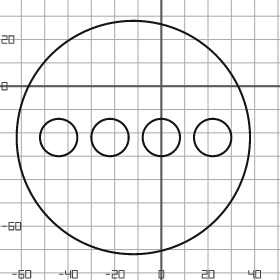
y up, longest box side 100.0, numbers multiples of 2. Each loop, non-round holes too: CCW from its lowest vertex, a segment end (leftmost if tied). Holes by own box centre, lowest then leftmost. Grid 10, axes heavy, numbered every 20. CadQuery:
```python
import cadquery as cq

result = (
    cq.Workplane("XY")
    .moveTo(-12.0, -22.0)
    .circle(50.0)
    .moveTo(-44.0, -22.0)
    .circle(8.0)
    .moveTo(-22.0, -22.0)
    .circle(8.0)
    .moveTo(0.0, -22.0)
    .circle(8.0)
    .moveTo(22.0, -22.0)
    .circle(8.0)
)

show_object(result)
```